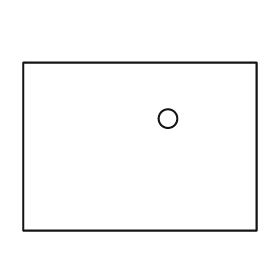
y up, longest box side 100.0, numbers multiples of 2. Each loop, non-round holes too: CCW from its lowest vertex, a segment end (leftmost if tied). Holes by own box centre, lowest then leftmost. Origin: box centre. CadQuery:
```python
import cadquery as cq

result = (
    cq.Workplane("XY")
    .moveTo(-50.0, -36.0)
    .lineTo(50.0, -36.0)
    .lineTo(50.0, 36.0)
    .lineTo(-50.0, 36.0)
    .close()
    .moveTo(12.0, 12.0)
    .circle(4.0)
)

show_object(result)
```